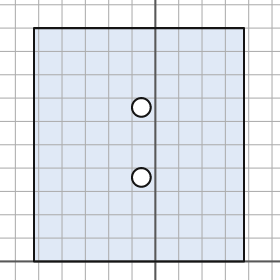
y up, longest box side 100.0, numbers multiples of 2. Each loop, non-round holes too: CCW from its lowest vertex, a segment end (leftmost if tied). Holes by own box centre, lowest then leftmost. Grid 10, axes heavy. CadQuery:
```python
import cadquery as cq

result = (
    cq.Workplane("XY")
    .moveTo(-52.0, 0.0)
    .lineTo(38.0, 0.0)
    .lineTo(38.0, 100.0)
    .lineTo(-52.0, 100.0)
    .close()
    .moveTo(-6.0, 36.0)
    .circle(4.0)
    .moveTo(-6.0, 66.0)
    .circle(4.0)
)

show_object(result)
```